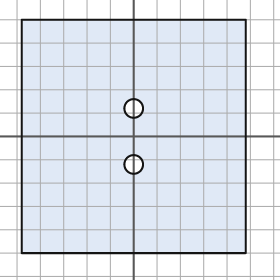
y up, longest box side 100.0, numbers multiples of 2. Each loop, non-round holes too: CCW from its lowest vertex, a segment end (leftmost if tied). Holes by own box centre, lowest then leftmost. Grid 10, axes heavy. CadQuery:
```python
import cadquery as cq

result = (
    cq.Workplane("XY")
    .moveTo(-48.0, -50.0)
    .lineTo(48.0, -50.0)
    .lineTo(48.0, 50.0)
    .lineTo(-48.0, 50.0)
    .close()
    .moveTo(0.0, -12.0)
    .circle(4.0)
    .moveTo(0.0, 12.0)
    .circle(4.0)
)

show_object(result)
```